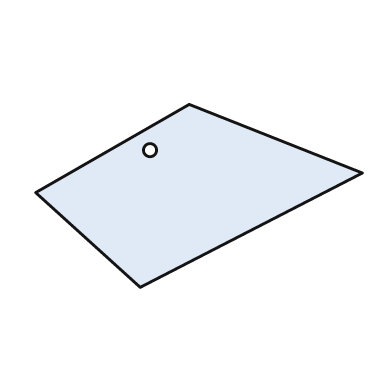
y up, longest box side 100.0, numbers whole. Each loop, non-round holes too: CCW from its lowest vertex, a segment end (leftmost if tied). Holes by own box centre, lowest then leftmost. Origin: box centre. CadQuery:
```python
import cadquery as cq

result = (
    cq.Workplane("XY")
    .moveTo(-18.0, -28.0)
    .lineTo(50.0, 7.0)
    .lineTo(-3.0, 28.0)
    .lineTo(-50.0, 1.0)
    .close()
    .moveTo(-15.0, 14.0)
    .circle(2.0)
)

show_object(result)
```